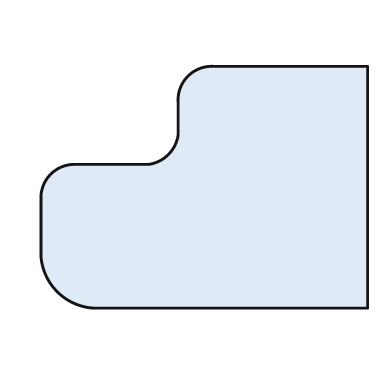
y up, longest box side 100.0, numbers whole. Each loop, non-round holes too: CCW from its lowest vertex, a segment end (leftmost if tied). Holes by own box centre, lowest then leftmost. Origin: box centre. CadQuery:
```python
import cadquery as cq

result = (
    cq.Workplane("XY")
    .moveTo(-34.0, -37.0)
    .lineTo(50.0, -37.0)
    .lineTo(50.0, 37.0)
    .lineTo(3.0, 37.0)
    .threePointArc((-5.0, 34.0), (-8.0, 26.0))
    .lineTo(-8.0, 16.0)
    .threePointArc((-11.0, 10.0), (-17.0, 7.0))
    .lineTo(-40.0, 7.0)
    .threePointArc((-47.0, 4.0), (-50.0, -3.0))
    .lineTo(-50.0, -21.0)
    .threePointArc((-45.0, -32.0), (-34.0, -37.0))
    .close()
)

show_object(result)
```